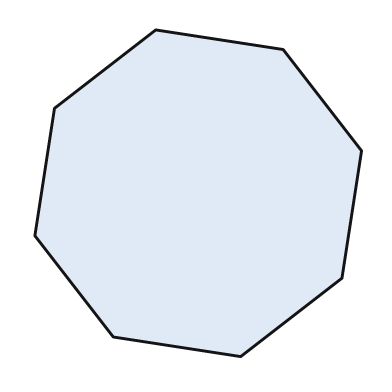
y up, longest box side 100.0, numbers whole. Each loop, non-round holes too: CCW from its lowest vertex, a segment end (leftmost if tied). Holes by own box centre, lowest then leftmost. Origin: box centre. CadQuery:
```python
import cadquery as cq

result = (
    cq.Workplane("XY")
    .moveTo(13.0, -50.0)
    .lineTo(44.0, -26.0)
    .lineTo(50.0, 13.0)
    .lineTo(26.0, 44.0)
    .lineTo(-13.0, 50.0)
    .lineTo(-44.0, 26.0)
    .lineTo(-50.0, -13.0)
    .lineTo(-26.0, -44.0)
    .close()
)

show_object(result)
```